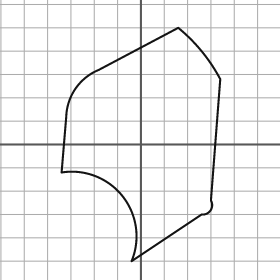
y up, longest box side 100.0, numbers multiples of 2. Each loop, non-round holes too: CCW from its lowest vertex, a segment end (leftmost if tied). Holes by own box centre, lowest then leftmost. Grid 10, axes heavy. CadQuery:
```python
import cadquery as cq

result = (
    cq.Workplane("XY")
    .moveTo(-4.0, -50.0)
    .lineTo(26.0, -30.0)
    .threePointArc((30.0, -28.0), (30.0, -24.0))
    .lineTo(34.0, 28.0)
    .threePointArc((26.0, 40.0), (16.0, 50.0))
    .lineTo(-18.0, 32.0)
    .threePointArc((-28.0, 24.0), (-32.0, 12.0))
    .lineTo(-34.0, -12.0)
    .threePointArc((-8.0, -22.0), (-4.0, -50.0))
    .close()
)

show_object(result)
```